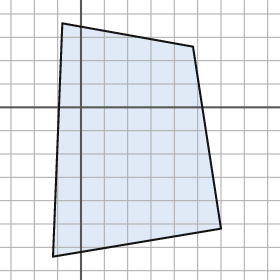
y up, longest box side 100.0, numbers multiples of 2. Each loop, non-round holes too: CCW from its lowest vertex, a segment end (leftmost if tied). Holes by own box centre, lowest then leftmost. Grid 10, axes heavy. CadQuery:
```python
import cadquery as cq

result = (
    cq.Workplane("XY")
    .moveTo(-12.0, -64.0)
    .lineTo(60.0, -52.0)
    .lineTo(48.0, 26.0)
    .lineTo(-8.0, 36.0)
    .close()
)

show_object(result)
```